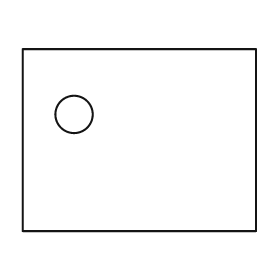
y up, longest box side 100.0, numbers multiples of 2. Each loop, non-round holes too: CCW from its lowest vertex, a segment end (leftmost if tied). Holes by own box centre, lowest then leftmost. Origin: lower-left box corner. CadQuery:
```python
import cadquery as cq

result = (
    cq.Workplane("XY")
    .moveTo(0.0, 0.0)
    .lineTo(100.0, 0.0)
    .lineTo(100.0, 78.0)
    .lineTo(0.0, 78.0)
    .close()
    .moveTo(22.0, 50.0)
    .circle(8.0)
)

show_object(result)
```